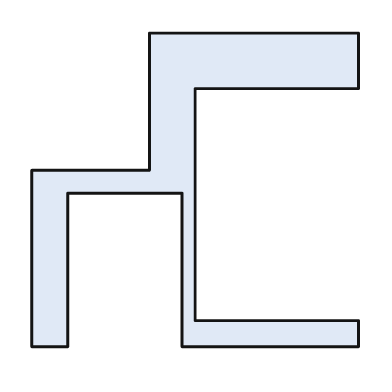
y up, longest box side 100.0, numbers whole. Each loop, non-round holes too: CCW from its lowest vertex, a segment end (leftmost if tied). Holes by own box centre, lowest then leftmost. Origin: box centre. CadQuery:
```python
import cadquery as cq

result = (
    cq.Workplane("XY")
    .moveTo(-50.0, -48.0)
    .lineTo(-39.0, -48.0)
    .lineTo(-39.0, -1.0)
    .lineTo(-4.0, -1.0)
    .lineTo(-4.0, -48.0)
    .lineTo(50.0, -48.0)
    .lineTo(50.0, -40.0)
    .lineTo(0.0, -40.0)
    .lineTo(0.0, 31.0)
    .lineTo(50.0, 31.0)
    .lineTo(50.0, 48.0)
    .lineTo(-14.0, 48.0)
    .lineTo(-14.0, 6.0)
    .lineTo(-50.0, 6.0)
    .close()
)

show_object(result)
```